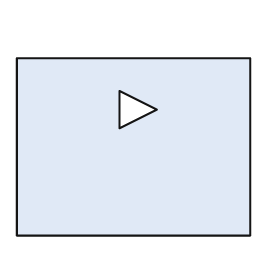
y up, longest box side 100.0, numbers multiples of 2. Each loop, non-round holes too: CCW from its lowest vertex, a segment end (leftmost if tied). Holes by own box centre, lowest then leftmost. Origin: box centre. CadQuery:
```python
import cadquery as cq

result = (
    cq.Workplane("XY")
    .moveTo(-50.0, -38.0)
    .lineTo(50.0, -38.0)
    .lineTo(50.0, 38.0)
    .lineTo(-50.0, 38.0)
    .close()
    .moveTo(-6.0, 8.0)
    .lineTo(10.0, 16.0)
    .lineTo(-6.0, 24.0)
    .close()
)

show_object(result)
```